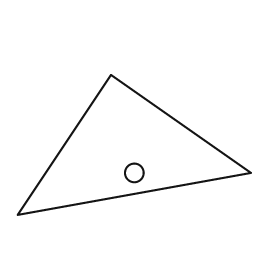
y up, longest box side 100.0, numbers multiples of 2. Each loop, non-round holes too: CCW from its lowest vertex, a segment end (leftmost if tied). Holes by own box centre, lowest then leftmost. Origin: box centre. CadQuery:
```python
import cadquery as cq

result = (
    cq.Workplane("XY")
    .moveTo(-50.0, -30.0)
    .lineTo(50.0, -12.0)
    .lineTo(-10.0, 30.0)
    .close()
    .moveTo(0.0, -12.0)
    .circle(4.0)
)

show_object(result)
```